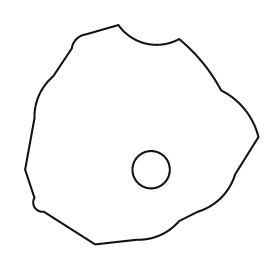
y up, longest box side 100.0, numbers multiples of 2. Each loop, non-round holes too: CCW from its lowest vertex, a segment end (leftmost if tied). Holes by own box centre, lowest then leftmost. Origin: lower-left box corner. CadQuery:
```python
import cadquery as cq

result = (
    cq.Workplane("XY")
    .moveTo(30.0, 0.0)
    .lineTo(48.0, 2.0)
    .threePointArc((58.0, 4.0), (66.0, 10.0))
    .lineTo(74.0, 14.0)
    .threePointArc((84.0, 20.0), (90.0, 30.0))
    .lineTo(100.0, 46.0)
    .threePointArc((94.0, 58.0), (84.0, 66.0))
    .threePointArc((76.0, 78.0), (66.0, 88.0))
    .threePointArc((52.0, 86.0), (40.0, 94.0))
    .lineTo(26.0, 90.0)
    .threePointArc((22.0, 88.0), (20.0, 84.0))
    .lineTo(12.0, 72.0)
    .threePointArc((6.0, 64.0), (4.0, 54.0))
    .lineTo(0.0, 32.0)
    .lineTo(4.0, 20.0)
    .threePointArc((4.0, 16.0), (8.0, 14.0))
    .close()
    .moveTo(54.0, 32.0)
    .circle(8.0)
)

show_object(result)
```